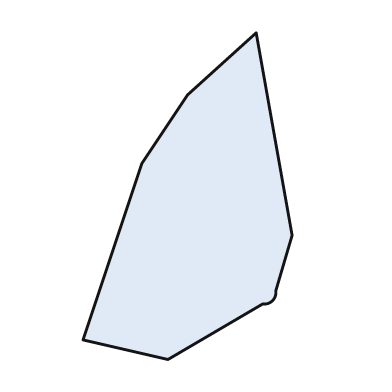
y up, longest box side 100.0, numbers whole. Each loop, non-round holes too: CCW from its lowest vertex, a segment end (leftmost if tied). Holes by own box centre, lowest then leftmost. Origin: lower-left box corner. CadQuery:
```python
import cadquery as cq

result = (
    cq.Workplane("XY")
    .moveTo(26.0, 0.0)
    .lineTo(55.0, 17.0)
    .threePointArc((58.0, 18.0), (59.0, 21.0))
    .lineTo(64.0, 38.0)
    .lineTo(53.0, 100.0)
    .lineTo(32.0, 81.0)
    .lineTo(18.0, 60.0)
    .lineTo(0.0, 6.0)
    .close()
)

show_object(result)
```